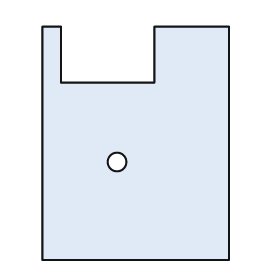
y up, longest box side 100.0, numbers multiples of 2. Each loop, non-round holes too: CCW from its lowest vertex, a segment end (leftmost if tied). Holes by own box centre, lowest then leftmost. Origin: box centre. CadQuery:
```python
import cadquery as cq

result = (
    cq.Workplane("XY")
    .moveTo(-40.0, -50.0)
    .lineTo(40.0, -50.0)
    .lineTo(40.0, 50.0)
    .lineTo(8.0, 50.0)
    .lineTo(8.0, 26.0)
    .lineTo(-32.0, 26.0)
    .lineTo(-32.0, 50.0)
    .lineTo(-40.0, 50.0)
    .close()
    .moveTo(-8.0, -8.0)
    .circle(4.0)
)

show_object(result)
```